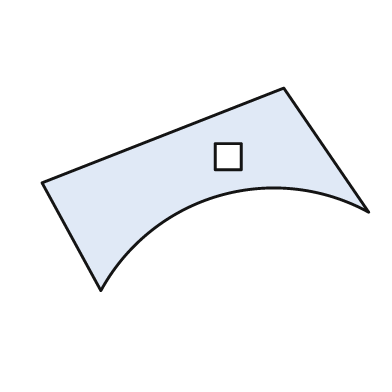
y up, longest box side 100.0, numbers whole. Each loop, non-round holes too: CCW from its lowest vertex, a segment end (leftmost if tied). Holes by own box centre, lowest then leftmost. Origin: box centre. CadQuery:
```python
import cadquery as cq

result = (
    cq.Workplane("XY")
    .moveTo(-32.0, -31.0)
    .threePointArc((4.0, -2.0), (50.0, -7.0))
    .lineTo(24.0, 31.0)
    .lineTo(-50.0, 2.0)
    .close()
    .moveTo(3.0, 6.0)
    .lineTo(11.0, 6.0)
    .lineTo(11.0, 14.0)
    .lineTo(3.0, 14.0)
    .close()
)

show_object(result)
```